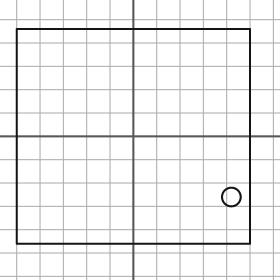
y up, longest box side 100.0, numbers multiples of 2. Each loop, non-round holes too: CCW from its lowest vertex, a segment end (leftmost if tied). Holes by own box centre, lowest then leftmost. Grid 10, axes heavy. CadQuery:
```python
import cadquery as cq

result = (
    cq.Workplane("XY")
    .moveTo(-50.0, -46.0)
    .lineTo(50.0, -46.0)
    .lineTo(50.0, 46.0)
    .lineTo(-50.0, 46.0)
    .close()
    .moveTo(42.0, -26.0)
    .circle(4.0)
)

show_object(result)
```